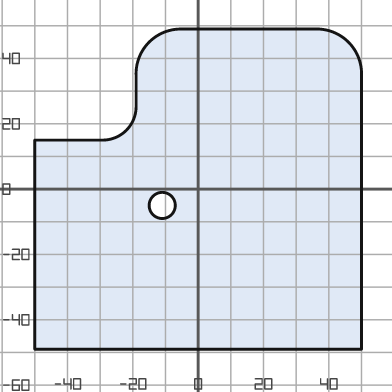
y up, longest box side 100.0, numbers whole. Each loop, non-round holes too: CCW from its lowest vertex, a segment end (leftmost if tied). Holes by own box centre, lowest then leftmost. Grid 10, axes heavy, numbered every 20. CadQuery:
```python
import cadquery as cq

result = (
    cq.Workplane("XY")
    .moveTo(-50.0, -49.0)
    .lineTo(50.0, -49.0)
    .lineTo(50.0, 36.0)
    .threePointArc((46.0, 45.0), (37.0, 49.0))
    .lineTo(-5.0, 49.0)
    .threePointArc((-15.0, 45.0), (-19.0, 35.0))
    .lineTo(-19.0, 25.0)
    .threePointArc((-22.0, 18.0), (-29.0, 15.0))
    .lineTo(-50.0, 15.0)
    .close()
    .moveTo(-11.0, -5.0)
    .circle(4.0)
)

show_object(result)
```